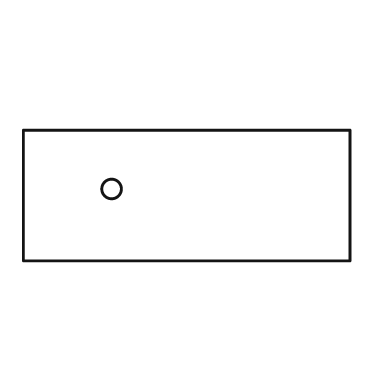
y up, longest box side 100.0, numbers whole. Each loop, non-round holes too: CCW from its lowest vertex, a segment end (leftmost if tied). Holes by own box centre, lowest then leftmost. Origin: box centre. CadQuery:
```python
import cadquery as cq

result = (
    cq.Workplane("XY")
    .moveTo(-50.0, -20.0)
    .lineTo(50.0, -20.0)
    .lineTo(50.0, 20.0)
    .lineTo(-50.0, 20.0)
    .close()
    .moveTo(-23.0, 2.0)
    .circle(3.0)
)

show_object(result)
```